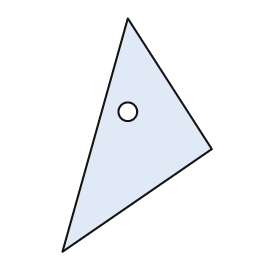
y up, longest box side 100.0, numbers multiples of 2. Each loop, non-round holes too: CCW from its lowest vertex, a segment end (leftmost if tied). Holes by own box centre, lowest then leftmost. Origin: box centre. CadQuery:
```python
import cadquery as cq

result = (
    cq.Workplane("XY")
    .moveTo(-32.0, -50.0)
    .lineTo(32.0, -6.0)
    .lineTo(-4.0, 50.0)
    .close()
    .moveTo(-4.0, 10.0)
    .circle(4.0)
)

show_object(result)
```